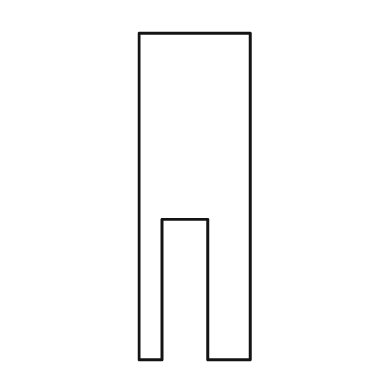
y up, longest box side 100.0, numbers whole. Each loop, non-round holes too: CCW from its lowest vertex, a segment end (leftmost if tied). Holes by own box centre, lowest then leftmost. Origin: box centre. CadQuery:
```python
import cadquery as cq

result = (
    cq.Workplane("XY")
    .moveTo(-17.0, -50.0)
    .lineTo(-10.0, -50.0)
    .lineTo(-10.0, -7.0)
    .lineTo(4.0, -7.0)
    .lineTo(4.0, -50.0)
    .lineTo(17.0, -50.0)
    .lineTo(17.0, 50.0)
    .lineTo(-17.0, 50.0)
    .close()
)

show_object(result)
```